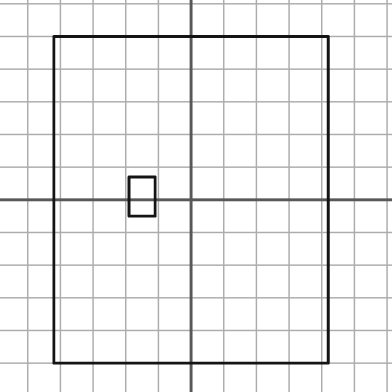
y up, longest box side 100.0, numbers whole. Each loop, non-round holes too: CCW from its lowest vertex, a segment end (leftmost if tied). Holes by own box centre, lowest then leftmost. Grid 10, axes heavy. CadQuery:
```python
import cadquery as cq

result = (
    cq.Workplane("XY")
    .moveTo(-42.0, -50.0)
    .lineTo(42.0, -50.0)
    .lineTo(42.0, 50.0)
    .lineTo(-42.0, 50.0)
    .close()
    .moveTo(-19.0, -5.0)
    .lineTo(-11.0, -5.0)
    .lineTo(-11.0, 7.0)
    .lineTo(-19.0, 7.0)
    .close()
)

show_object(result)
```